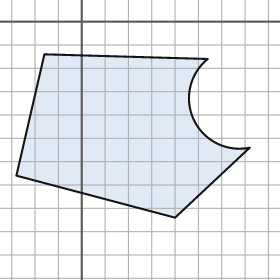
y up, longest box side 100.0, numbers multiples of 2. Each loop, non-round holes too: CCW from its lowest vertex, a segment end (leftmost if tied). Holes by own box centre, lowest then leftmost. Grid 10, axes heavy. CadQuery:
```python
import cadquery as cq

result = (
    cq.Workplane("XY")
    .moveTo(40.0, -84.0)
    .lineTo(72.0, -54.0)
    .threePointArc((48.0, -42.0), (54.0, -16.0))
    .lineTo(-16.0, -14.0)
    .lineTo(-28.0, -66.0)
    .close()
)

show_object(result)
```